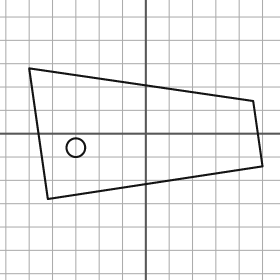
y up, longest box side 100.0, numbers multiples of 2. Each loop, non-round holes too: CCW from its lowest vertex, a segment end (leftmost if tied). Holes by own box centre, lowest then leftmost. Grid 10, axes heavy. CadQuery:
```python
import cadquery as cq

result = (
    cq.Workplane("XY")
    .moveTo(-42.0, -28.0)
    .lineTo(50.0, -14.0)
    .lineTo(46.0, 14.0)
    .lineTo(-50.0, 28.0)
    .close()
    .moveTo(-30.0, -6.0)
    .circle(4.0)
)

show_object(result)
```